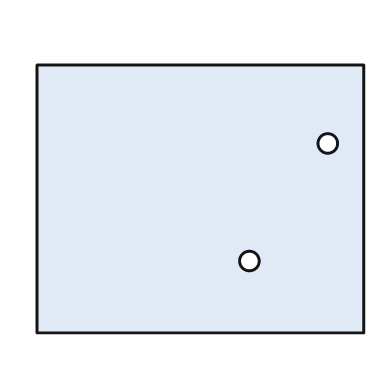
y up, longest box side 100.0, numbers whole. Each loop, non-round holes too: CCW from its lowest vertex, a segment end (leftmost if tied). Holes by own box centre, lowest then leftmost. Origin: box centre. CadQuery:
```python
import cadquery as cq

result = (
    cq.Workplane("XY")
    .moveTo(-50.0, -41.0)
    .lineTo(50.0, -41.0)
    .lineTo(50.0, 41.0)
    .lineTo(-50.0, 41.0)
    .close()
    .moveTo(15.0, -19.0)
    .circle(3.0)
    .moveTo(39.0, 17.0)
    .circle(3.0)
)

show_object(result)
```